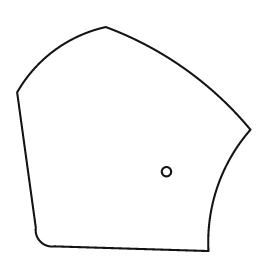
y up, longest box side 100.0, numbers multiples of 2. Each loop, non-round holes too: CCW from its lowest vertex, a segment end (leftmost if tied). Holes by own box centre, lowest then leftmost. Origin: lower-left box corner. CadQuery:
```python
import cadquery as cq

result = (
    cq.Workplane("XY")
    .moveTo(82.0, 0.0)
    .threePointArc((86.0, 28.0), (100.0, 52.0))
    .threePointArc((72.0, 78.0), (38.0, 96.0))
    .threePointArc((16.0, 86.0), (0.0, 68.0))
    .lineTo(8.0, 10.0)
    .threePointArc((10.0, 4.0), (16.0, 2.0))
    .close()
    .moveTo(64.0, 34.0)
    .circle(2.0)
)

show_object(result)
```